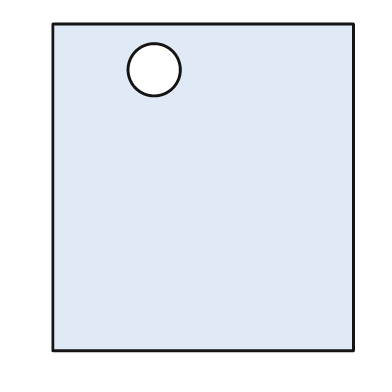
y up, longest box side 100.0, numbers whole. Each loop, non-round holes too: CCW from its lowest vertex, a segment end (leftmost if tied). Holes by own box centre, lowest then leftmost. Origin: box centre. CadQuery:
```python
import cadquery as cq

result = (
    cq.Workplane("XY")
    .moveTo(-46.0, -50.0)
    .lineTo(46.0, -50.0)
    .lineTo(46.0, 50.0)
    .lineTo(-46.0, 50.0)
    .close()
    .moveTo(-15.0, 36.0)
    .circle(8.0)
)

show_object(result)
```